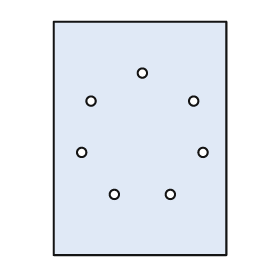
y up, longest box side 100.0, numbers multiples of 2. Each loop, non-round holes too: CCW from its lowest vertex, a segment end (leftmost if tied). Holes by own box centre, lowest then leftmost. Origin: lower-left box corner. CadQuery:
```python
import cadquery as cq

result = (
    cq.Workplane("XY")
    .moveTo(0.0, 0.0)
    .lineTo(74.0, 0.0)
    .lineTo(74.0, 100.0)
    .lineTo(0.0, 100.0)
    .close()
    .moveTo(26.0, 26.0)
    .circle(2.0)
    .moveTo(50.0, 26.0)
    .circle(2.0)
    .moveTo(12.0, 44.0)
    .circle(2.0)
    .moveTo(64.0, 44.0)
    .circle(2.0)
    .moveTo(16.0, 66.0)
    .circle(2.0)
    .moveTo(60.0, 66.0)
    .circle(2.0)
    .moveTo(38.0, 78.0)
    .circle(2.0)
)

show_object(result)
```